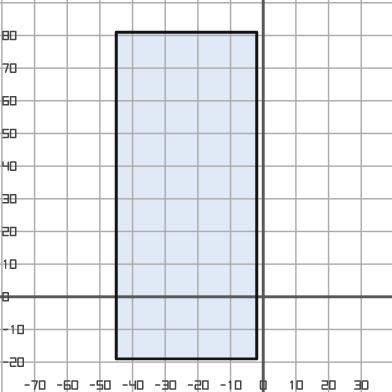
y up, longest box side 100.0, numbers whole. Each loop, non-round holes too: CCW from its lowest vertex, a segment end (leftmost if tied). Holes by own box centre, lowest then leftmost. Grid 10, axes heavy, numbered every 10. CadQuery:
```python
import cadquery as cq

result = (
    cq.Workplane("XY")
    .moveTo(-45.0, -19.0)
    .lineTo(-2.0, -19.0)
    .lineTo(-2.0, 81.0)
    .lineTo(-45.0, 81.0)
    .close()
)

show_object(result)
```